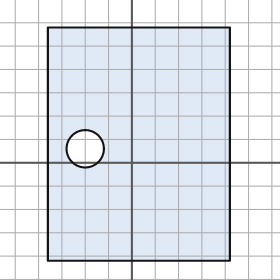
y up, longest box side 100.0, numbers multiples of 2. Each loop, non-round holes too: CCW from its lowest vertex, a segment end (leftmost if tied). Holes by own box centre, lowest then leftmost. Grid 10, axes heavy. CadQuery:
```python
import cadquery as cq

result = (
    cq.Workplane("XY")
    .moveTo(-36.0, -42.0)
    .lineTo(42.0, -42.0)
    .lineTo(42.0, 58.0)
    .lineTo(-36.0, 58.0)
    .close()
    .moveTo(-20.0, 6.0)
    .circle(8.0)
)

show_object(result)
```